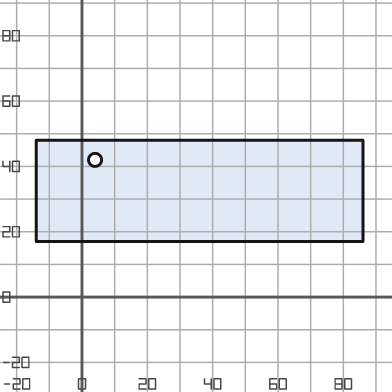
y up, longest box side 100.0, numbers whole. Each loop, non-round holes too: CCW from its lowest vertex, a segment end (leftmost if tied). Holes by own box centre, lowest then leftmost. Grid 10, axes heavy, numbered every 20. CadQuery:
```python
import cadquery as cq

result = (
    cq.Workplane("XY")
    .moveTo(-14.0, 17.0)
    .lineTo(86.0, 17.0)
    .lineTo(86.0, 48.0)
    .lineTo(-14.0, 48.0)
    .close()
    .moveTo(4.0, 42.0)
    .circle(2.0)
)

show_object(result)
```